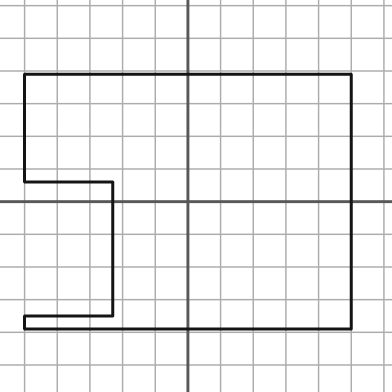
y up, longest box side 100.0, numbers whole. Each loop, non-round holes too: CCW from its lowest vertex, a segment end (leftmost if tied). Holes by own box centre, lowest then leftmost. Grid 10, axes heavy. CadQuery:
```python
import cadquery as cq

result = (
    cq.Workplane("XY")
    .moveTo(-50.0, -39.0)
    .lineTo(50.0, -39.0)
    .lineTo(50.0, 39.0)
    .lineTo(-50.0, 39.0)
    .lineTo(-50.0, 6.0)
    .lineTo(-23.0, 6.0)
    .lineTo(-23.0, -35.0)
    .lineTo(-50.0, -35.0)
    .close()
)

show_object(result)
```